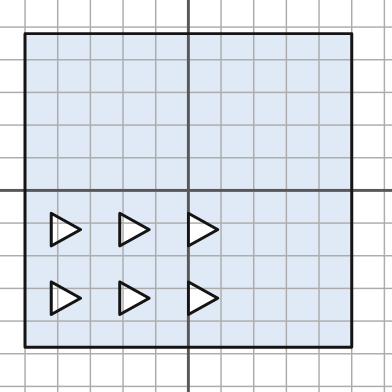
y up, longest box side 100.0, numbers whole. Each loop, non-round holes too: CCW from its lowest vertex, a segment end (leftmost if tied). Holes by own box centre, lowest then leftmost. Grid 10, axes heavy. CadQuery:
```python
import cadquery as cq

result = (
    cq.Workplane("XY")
    .moveTo(-50.0, -48.0)
    .lineTo(50.0, -48.0)
    .lineTo(50.0, 48.0)
    .lineTo(-50.0, 48.0)
    .close()
    .moveTo(-42.0, -38.0)
    .lineTo(-33.0, -33.0)
    .lineTo(-42.0, -28.0)
    .close()
    .moveTo(-21.0, -38.0)
    .lineTo(-12.0, -33.0)
    .lineTo(-21.0, -28.0)
    .close()
    .moveTo(0.0, -38.0)
    .lineTo(9.0, -33.0)
    .lineTo(0.0, -28.0)
    .close()
    .moveTo(-42.0, -17.0)
    .lineTo(-33.0, -12.0)
    .lineTo(-42.0, -7.0)
    .close()
    .moveTo(-21.0, -17.0)
    .lineTo(-12.0, -12.0)
    .lineTo(-21.0, -7.0)
    .close()
    .moveTo(0.0, -17.0)
    .lineTo(9.0, -12.0)
    .lineTo(0.0, -7.0)
    .close()
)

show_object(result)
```